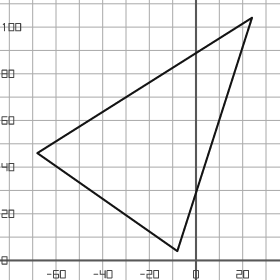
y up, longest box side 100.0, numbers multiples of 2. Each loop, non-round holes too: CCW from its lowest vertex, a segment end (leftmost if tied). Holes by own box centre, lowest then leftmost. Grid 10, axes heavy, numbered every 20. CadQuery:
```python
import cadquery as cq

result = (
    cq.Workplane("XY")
    .moveTo(-8.0, 4.0)
    .lineTo(24.0, 104.0)
    .lineTo(-68.0, 46.0)
    .close()
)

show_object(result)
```